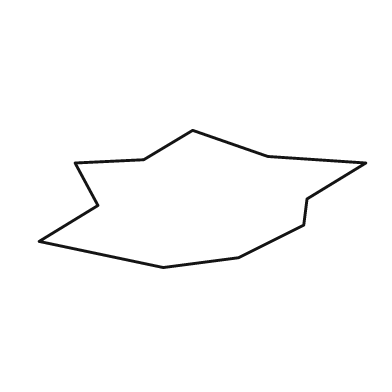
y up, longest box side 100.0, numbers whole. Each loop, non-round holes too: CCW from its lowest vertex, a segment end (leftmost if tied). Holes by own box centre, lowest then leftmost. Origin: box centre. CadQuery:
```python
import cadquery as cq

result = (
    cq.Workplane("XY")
    .moveTo(-12.0, -21.0)
    .lineTo(11.0, -18.0)
    .lineTo(31.0, -8.0)
    .lineTo(32.0, 0.0)
    .lineTo(50.0, 11.0)
    .lineTo(20.0, 13.0)
    .lineTo(-3.0, 21.0)
    .lineTo(-18.0, 12.0)
    .lineTo(-39.0, 11.0)
    .lineTo(-32.0, -2.0)
    .lineTo(-50.0, -13.0)
    .close()
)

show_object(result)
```